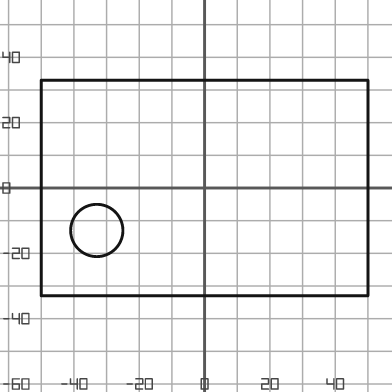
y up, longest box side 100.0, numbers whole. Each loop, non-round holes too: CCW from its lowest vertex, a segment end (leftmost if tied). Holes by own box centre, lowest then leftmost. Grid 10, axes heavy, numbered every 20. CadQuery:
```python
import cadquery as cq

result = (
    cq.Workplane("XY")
    .moveTo(-50.0, -33.0)
    .lineTo(50.0, -33.0)
    .lineTo(50.0, 33.0)
    .lineTo(-50.0, 33.0)
    .close()
    .moveTo(-33.0, -13.0)
    .circle(8.0)
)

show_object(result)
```